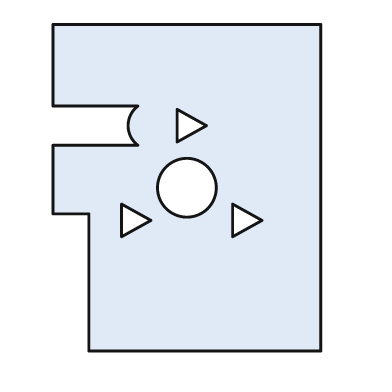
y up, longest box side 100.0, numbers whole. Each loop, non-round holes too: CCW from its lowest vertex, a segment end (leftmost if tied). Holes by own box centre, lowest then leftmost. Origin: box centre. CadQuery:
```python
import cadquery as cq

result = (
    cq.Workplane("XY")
    .moveTo(-30.0, -50.0)
    .lineTo(41.0, -50.0)
    .lineTo(41.0, 50.0)
    .lineTo(-41.0, 50.0)
    .lineTo(-41.0, 25.0)
    .lineTo(-15.0, 25.0)
    .threePointArc((-18.0, 19.0), (-15.0, 13.0))
    .lineTo(-41.0, 13.0)
    .lineTo(-41.0, -8.0)
    .lineTo(-30.0, -8.0)
    .close()
    .moveTo(-20.0, -15.0)
    .lineTo(-11.0, -10.0)
    .lineTo(-20.0, -5.0)
    .close()
    .moveTo(14.0, -15.0)
    .lineTo(23.0, -10.0)
    .lineTo(14.0, -5.0)
    .close()
    .moveTo(0.0, 0.0)
    .circle(9.0)
    .moveTo(-3.0, 14.0)
    .lineTo(6.0, 19.0)
    .lineTo(-3.0, 24.0)
    .close()
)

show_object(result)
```